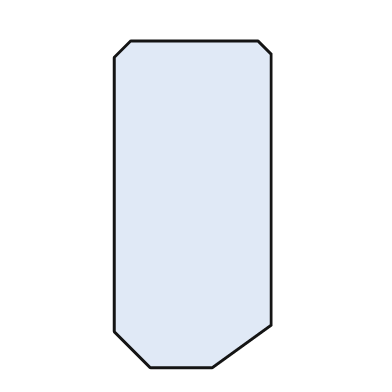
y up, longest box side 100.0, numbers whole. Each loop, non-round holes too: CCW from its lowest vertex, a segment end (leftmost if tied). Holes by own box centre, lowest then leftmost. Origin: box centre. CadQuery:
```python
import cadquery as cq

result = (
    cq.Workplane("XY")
    .moveTo(-13.0, -50.0)
    .lineTo(6.0, -50.0)
    .lineTo(24.0, -37.0)
    .lineTo(24.0, 46.0)
    .lineTo(20.0, 50.0)
    .lineTo(-19.0, 50.0)
    .lineTo(-24.0, 45.0)
    .lineTo(-24.0, -39.0)
    .close()
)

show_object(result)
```